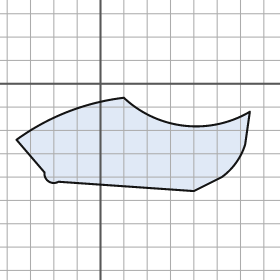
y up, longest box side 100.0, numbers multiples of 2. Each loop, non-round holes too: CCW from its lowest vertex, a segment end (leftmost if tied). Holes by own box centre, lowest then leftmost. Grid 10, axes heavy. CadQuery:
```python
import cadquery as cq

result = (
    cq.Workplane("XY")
    .moveTo(40.0, -46.0)
    .lineTo(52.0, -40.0)
    .threePointArc((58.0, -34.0), (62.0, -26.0))
    .lineTo(64.0, -12.0)
    .threePointArc((36.0, -18.0), (10.0, -6.0))
    .threePointArc((-14.0, -12.0), (-36.0, -24.0))
    .lineTo(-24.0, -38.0)
    .threePointArc((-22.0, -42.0), (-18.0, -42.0))
    .close()
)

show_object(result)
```